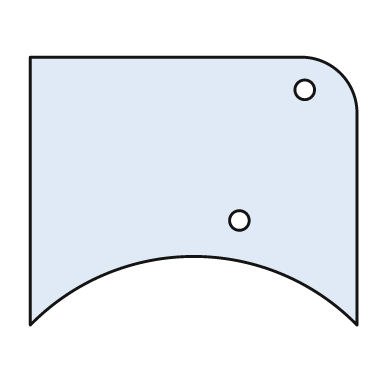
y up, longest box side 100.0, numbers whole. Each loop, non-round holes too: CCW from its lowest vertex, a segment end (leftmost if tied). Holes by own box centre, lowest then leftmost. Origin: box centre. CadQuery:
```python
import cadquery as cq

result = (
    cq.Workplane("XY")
    .moveTo(-50.0, -41.0)
    .threePointArc((0.0, -20.0), (50.0, -41.0))
    .lineTo(50.0, 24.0)
    .threePointArc((45.0, 36.0), (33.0, 41.0))
    .lineTo(-50.0, 41.0)
    .close()
    .moveTo(14.0, -9.0)
    .circle(3.0)
    .moveTo(34.0, 31.0)
    .circle(3.0)
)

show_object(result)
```